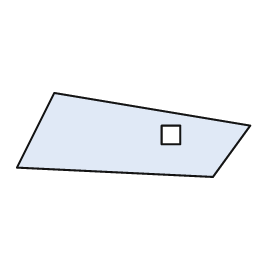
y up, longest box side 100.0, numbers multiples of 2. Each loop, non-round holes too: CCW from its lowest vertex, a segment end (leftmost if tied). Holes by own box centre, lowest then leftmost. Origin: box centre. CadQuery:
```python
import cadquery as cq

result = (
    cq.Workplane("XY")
    .moveTo(34.0, -18.0)
    .lineTo(50.0, 4.0)
    .lineTo(-34.0, 18.0)
    .lineTo(-50.0, -14.0)
    .close()
    .moveTo(12.0, -4.0)
    .lineTo(20.0, -4.0)
    .lineTo(20.0, 4.0)
    .lineTo(12.0, 4.0)
    .close()
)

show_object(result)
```